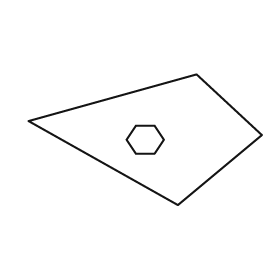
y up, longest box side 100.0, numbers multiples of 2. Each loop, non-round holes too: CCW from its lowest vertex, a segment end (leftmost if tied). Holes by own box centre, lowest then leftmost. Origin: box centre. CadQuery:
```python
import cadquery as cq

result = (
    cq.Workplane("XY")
    .moveTo(14.0, -28.0)
    .lineTo(50.0, 2.0)
    .lineTo(22.0, 28.0)
    .lineTo(-50.0, 8.0)
    .close()
    .moveTo(-4.0, -6.0)
    .lineTo(4.0, -6.0)
    .lineTo(8.0, 0.0)
    .lineTo(4.0, 6.0)
    .lineTo(-4.0, 6.0)
    .lineTo(-8.0, 0.0)
    .close()
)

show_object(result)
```